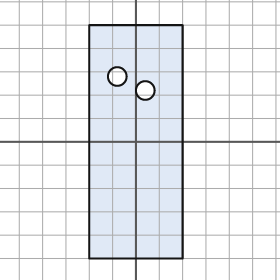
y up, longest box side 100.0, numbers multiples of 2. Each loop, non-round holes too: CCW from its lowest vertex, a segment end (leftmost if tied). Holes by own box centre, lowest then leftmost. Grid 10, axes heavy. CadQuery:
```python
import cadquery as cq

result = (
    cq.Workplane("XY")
    .moveTo(-20.0, -50.0)
    .lineTo(20.0, -50.0)
    .lineTo(20.0, 50.0)
    .lineTo(-20.0, 50.0)
    .close()
    .moveTo(4.0, 22.0)
    .circle(4.0)
    .moveTo(-8.0, 28.0)
    .circle(4.0)
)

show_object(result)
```